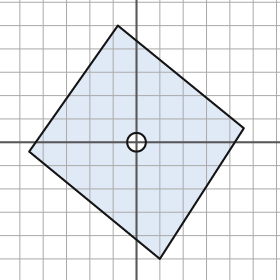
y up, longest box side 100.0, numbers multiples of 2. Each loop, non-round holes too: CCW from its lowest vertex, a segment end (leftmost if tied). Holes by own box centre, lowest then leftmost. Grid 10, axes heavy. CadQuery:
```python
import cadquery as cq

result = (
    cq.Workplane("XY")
    .moveTo(10.0, -50.0)
    .lineTo(46.0, 6.0)
    .lineTo(-8.0, 50.0)
    .lineTo(-46.0, -4.0)
    .close()
    .moveTo(0.0, 0.0)
    .circle(4.0)
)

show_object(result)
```